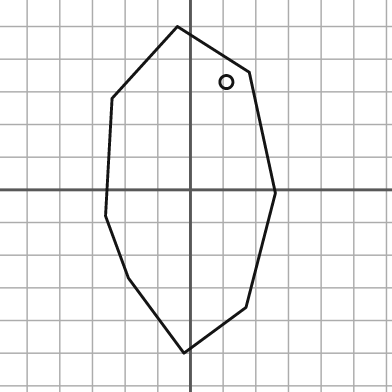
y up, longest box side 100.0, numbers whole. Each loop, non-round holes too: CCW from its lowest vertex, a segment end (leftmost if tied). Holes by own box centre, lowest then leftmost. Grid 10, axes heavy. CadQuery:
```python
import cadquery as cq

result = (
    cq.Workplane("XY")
    .moveTo(-2.0, -50.0)
    .lineTo(17.0, -36.0)
    .lineTo(26.0, -1.0)
    .lineTo(18.0, 36.0)
    .lineTo(-4.0, 50.0)
    .lineTo(-24.0, 28.0)
    .lineTo(-26.0, -8.0)
    .lineTo(-19.0, -27.0)
    .close()
    .moveTo(11.0, 33.0)
    .circle(2.0)
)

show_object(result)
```